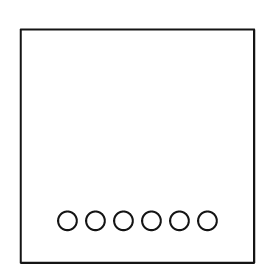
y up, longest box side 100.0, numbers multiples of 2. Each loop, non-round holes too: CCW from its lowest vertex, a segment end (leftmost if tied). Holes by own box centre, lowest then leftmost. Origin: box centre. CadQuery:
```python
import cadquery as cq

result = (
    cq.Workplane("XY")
    .moveTo(-50.0, -50.0)
    .lineTo(50.0, -50.0)
    .lineTo(50.0, 50.0)
    .lineTo(-50.0, 50.0)
    .close()
    .moveTo(-30.0, -32.0)
    .circle(4.0)
    .moveTo(-18.0, -32.0)
    .circle(4.0)
    .moveTo(-6.0, -32.0)
    .circle(4.0)
    .moveTo(6.0, -32.0)
    .circle(4.0)
    .moveTo(18.0, -32.0)
    .circle(4.0)
    .moveTo(30.0, -32.0)
    .circle(4.0)
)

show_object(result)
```